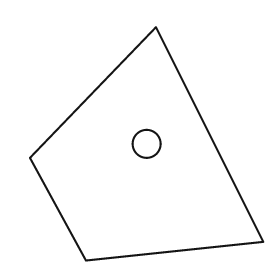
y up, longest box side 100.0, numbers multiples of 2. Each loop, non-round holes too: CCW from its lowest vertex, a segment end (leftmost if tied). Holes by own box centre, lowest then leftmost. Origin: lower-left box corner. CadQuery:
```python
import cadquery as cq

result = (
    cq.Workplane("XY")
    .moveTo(24.0, 0.0)
    .lineTo(100.0, 8.0)
    .lineTo(54.0, 100.0)
    .lineTo(0.0, 44.0)
    .close()
    .moveTo(50.0, 50.0)
    .circle(6.0)
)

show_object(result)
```